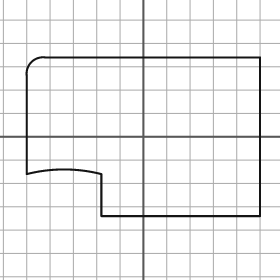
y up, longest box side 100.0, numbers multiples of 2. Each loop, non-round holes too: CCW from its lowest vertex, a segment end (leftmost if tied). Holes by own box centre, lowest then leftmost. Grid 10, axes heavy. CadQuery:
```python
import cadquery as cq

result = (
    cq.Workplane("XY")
    .moveTo(-18.0, -34.0)
    .lineTo(50.0, -34.0)
    .lineTo(50.0, 34.0)
    .lineTo(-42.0, 34.0)
    .threePointArc((-48.0, 32.0), (-50.0, 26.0))
    .lineTo(-50.0, -16.0)
    .threePointArc((-34.0, -14.0), (-18.0, -16.0))
    .close()
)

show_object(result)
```